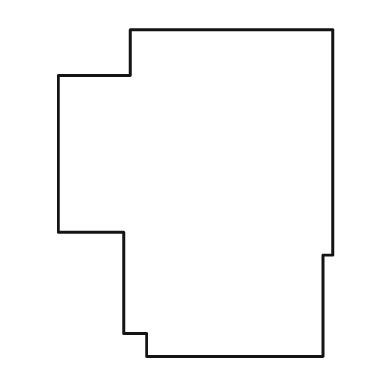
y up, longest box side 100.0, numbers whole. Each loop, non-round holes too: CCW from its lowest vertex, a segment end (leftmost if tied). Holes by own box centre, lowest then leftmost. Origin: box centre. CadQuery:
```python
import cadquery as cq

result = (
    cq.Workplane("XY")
    .moveTo(-15.0, -50.0)
    .lineTo(39.0, -50.0)
    .lineTo(39.0, -19.0)
    .lineTo(42.0, -19.0)
    .lineTo(42.0, 50.0)
    .lineTo(-20.0, 50.0)
    .lineTo(-20.0, 36.0)
    .lineTo(-42.0, 36.0)
    .lineTo(-42.0, -12.0)
    .lineTo(-22.0, -12.0)
    .lineTo(-22.0, -43.0)
    .lineTo(-15.0, -43.0)
    .close()
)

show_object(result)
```